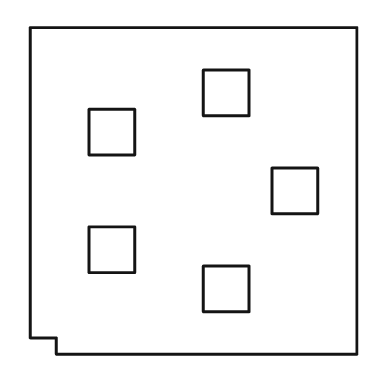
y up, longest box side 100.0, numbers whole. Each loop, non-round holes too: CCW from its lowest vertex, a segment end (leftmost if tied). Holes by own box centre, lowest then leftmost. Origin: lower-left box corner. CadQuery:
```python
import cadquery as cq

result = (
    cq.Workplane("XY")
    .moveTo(8.0, 0.0)
    .lineTo(100.0, 0.0)
    .lineTo(100.0, 100.0)
    .lineTo(0.0, 100.0)
    .lineTo(0.0, 5.0)
    .lineTo(8.0, 5.0)
    .close()
    .moveTo(53.0, 13.0)
    .lineTo(67.0, 13.0)
    .lineTo(67.0, 27.0)
    .lineTo(53.0, 27.0)
    .close()
    .moveTo(18.0, 25.0)
    .lineTo(32.0, 25.0)
    .lineTo(32.0, 39.0)
    .lineTo(18.0, 39.0)
    .close()
    .moveTo(74.0, 43.0)
    .lineTo(88.0, 43.0)
    .lineTo(88.0, 57.0)
    .lineTo(74.0, 57.0)
    .close()
    .moveTo(18.0, 61.0)
    .lineTo(32.0, 61.0)
    .lineTo(32.0, 75.0)
    .lineTo(18.0, 75.0)
    .close()
    .moveTo(53.0, 73.0)
    .lineTo(67.0, 73.0)
    .lineTo(67.0, 87.0)
    .lineTo(53.0, 87.0)
    .close()
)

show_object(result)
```